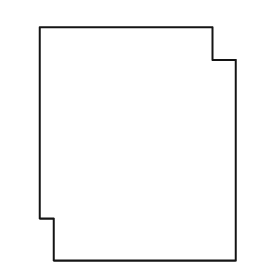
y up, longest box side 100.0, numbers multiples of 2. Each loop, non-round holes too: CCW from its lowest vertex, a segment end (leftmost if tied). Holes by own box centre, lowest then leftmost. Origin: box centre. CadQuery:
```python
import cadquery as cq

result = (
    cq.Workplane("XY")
    .moveTo(-36.0, -50.0)
    .lineTo(42.0, -50.0)
    .lineTo(42.0, 36.0)
    .lineTo(32.0, 36.0)
    .lineTo(32.0, 50.0)
    .lineTo(-42.0, 50.0)
    .lineTo(-42.0, -32.0)
    .lineTo(-36.0, -32.0)
    .close()
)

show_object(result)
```